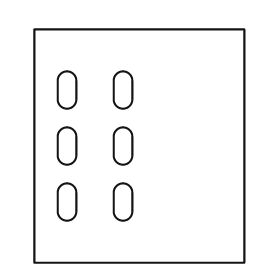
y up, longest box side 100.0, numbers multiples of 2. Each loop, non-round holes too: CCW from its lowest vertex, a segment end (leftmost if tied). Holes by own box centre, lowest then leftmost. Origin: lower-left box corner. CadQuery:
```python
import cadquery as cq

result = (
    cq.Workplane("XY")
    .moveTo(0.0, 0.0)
    .lineTo(90.0, 0.0)
    .lineTo(90.0, 100.0)
    .lineTo(0.0, 100.0)
    .close()
    .moveTo(10.0, 22.0)
    .threePointArc((14.0, 18.0), (18.0, 22.0))
    .lineTo(18.0, 30.0)
    .threePointArc((14.0, 34.0), (10.0, 30.0))
    .close()
    .moveTo(34.0, 22.0)
    .threePointArc((38.0, 18.0), (42.0, 22.0))
    .lineTo(42.0, 30.0)
    .threePointArc((38.0, 34.0), (34.0, 30.0))
    .close()
    .moveTo(10.0, 46.0)
    .threePointArc((14.0, 42.0), (18.0, 46.0))
    .lineTo(18.0, 54.0)
    .threePointArc((14.0, 58.0), (10.0, 54.0))
    .close()
    .moveTo(34.0, 46.0)
    .threePointArc((38.0, 42.0), (42.0, 46.0))
    .lineTo(42.0, 54.0)
    .threePointArc((38.0, 58.0), (34.0, 54.0))
    .close()
    .moveTo(10.0, 70.0)
    .threePointArc((14.0, 66.0), (18.0, 70.0))
    .lineTo(18.0, 78.0)
    .threePointArc((14.0, 82.0), (10.0, 78.0))
    .close()
    .moveTo(34.0, 70.0)
    .threePointArc((38.0, 66.0), (42.0, 70.0))
    .lineTo(42.0, 78.0)
    .threePointArc((38.0, 82.0), (34.0, 78.0))
    .close()
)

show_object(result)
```